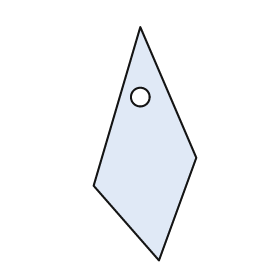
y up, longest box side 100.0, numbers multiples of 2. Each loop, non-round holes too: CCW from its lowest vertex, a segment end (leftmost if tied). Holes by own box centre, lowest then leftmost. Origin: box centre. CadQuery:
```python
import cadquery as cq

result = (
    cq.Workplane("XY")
    .moveTo(6.0, -50.0)
    .lineTo(22.0, -6.0)
    .lineTo(-2.0, 50.0)
    .lineTo(-22.0, -18.0)
    .close()
    .moveTo(-2.0, 20.0)
    .circle(4.0)
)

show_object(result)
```